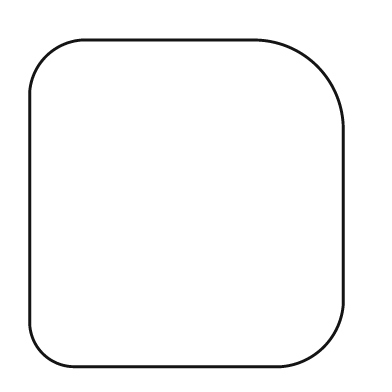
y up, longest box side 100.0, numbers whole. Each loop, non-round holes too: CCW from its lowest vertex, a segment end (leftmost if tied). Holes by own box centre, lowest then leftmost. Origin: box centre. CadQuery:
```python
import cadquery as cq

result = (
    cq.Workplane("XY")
    .moveTo(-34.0, -50.0)
    .lineTo(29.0, -50.0)
    .threePointArc((42.0, -44.0), (48.0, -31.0))
    .lineTo(48.0, 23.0)
    .threePointArc((40.0, 42.0), (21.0, 50.0))
    .lineTo(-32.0, 50.0)
    .threePointArc((-43.0, 45.0), (-48.0, 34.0))
    .lineTo(-48.0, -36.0)
    .threePointArc((-44.0, -46.0), (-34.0, -50.0))
    .close()
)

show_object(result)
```